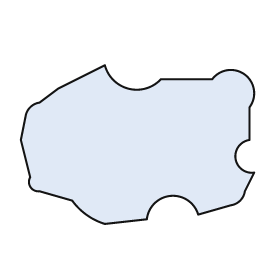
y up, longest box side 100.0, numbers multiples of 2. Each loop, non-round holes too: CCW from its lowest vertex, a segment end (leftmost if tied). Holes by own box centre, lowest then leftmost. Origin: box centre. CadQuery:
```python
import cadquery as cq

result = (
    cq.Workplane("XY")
    .moveTo(-14.0, -34.0)
    .lineTo(4.0, -32.0)
    .threePointArc((14.0, -22.0), (26.0, -30.0))
    .lineTo(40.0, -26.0)
    .threePointArc((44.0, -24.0), (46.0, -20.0))
    .lineTo(50.0, -12.0)
    .threePointArc((42.0, -6.0), (48.0, 2.0))
    .lineTo(48.0, 16.0)
    .threePointArc((46.0, 30.0), (32.0, 28.0))
    .lineTo(10.0, 28.0)
    .threePointArc((-4.0, 24.0), (-14.0, 34.0))
    .lineTo(-34.0, 24.0)
    .lineTo(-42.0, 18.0)
    .threePointArc((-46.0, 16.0), (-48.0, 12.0))
    .lineTo(-50.0, 2.0)
    .lineTo(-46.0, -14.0)
    .threePointArc((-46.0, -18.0), (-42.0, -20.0))
    .lineTo(-28.0, -24.0)
    .threePointArc((-22.0, -30.0), (-14.0, -34.0))
    .close()
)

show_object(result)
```